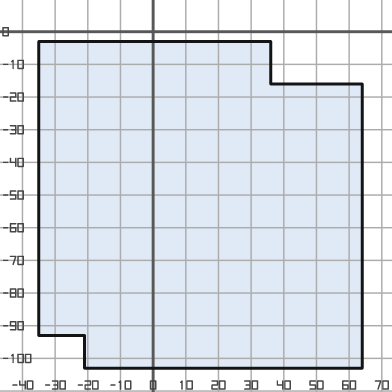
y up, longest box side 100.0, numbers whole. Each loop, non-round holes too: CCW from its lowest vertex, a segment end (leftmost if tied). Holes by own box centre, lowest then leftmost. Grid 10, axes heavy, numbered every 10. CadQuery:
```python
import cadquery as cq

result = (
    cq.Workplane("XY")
    .moveTo(-21.0, -103.0)
    .lineTo(64.0, -103.0)
    .lineTo(64.0, -16.0)
    .lineTo(36.0, -16.0)
    .lineTo(36.0, -3.0)
    .lineTo(-35.0, -3.0)
    .lineTo(-35.0, -93.0)
    .lineTo(-21.0, -93.0)
    .close()
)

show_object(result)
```